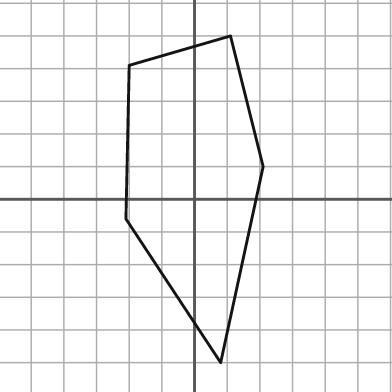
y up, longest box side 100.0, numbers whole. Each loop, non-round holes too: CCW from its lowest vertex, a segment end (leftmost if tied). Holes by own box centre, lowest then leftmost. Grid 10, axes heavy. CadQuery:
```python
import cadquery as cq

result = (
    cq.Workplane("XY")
    .moveTo(8.0, -50.0)
    .lineTo(21.0, 10.0)
    .lineTo(11.0, 50.0)
    .lineTo(-20.0, 41.0)
    .lineTo(-21.0, -6.0)
    .close()
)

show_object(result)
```